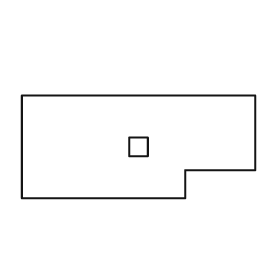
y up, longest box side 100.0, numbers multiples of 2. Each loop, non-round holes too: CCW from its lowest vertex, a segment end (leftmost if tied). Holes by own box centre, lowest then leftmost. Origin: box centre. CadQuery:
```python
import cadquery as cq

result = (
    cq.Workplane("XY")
    .moveTo(-50.0, -22.0)
    .lineTo(20.0, -22.0)
    .lineTo(20.0, -10.0)
    .lineTo(50.0, -10.0)
    .lineTo(50.0, 22.0)
    .lineTo(-50.0, 22.0)
    .close()
    .moveTo(-4.0, -4.0)
    .lineTo(4.0, -4.0)
    .lineTo(4.0, 4.0)
    .lineTo(-4.0, 4.0)
    .close()
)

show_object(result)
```